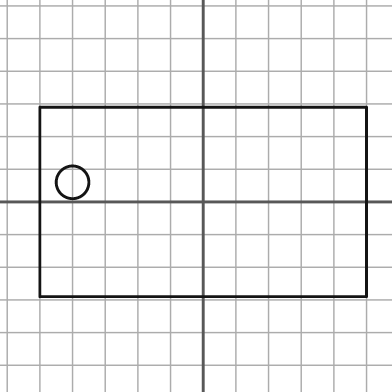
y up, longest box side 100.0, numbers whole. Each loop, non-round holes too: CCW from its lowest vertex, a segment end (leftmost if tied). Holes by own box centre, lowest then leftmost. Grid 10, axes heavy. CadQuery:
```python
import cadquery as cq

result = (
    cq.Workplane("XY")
    .moveTo(-50.0, -29.0)
    .lineTo(50.0, -29.0)
    .lineTo(50.0, 29.0)
    .lineTo(-50.0, 29.0)
    .close()
    .moveTo(-40.0, 6.0)
    .circle(5.0)
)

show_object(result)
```